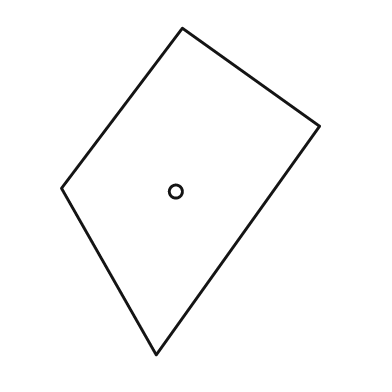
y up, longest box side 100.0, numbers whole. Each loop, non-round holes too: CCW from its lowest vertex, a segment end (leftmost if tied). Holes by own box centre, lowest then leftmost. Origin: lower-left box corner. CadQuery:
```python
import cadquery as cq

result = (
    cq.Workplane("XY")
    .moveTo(29.0, 0.0)
    .lineTo(79.0, 70.0)
    .lineTo(37.0, 100.0)
    .lineTo(0.0, 51.0)
    .close()
    .moveTo(35.0, 50.0)
    .circle(2.0)
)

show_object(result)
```